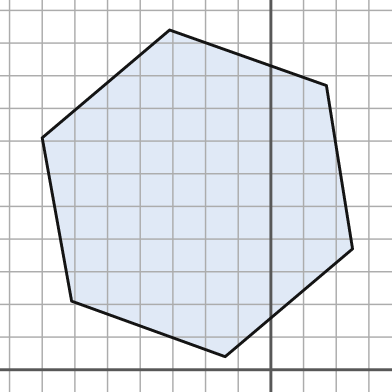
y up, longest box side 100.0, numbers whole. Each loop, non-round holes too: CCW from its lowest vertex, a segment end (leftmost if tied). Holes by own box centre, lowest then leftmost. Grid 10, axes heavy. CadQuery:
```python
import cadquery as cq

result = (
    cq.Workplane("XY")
    .moveTo(-14.0, 4.0)
    .lineTo(25.0, 37.0)
    .lineTo(17.0, 87.0)
    .lineTo(-31.0, 104.0)
    .lineTo(-70.0, 71.0)
    .lineTo(-61.0, 21.0)
    .close()
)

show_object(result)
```